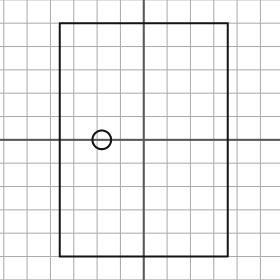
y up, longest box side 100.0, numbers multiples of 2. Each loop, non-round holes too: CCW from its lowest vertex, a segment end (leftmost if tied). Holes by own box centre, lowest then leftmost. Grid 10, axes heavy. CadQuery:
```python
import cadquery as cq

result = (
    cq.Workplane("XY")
    .moveTo(-36.0, -50.0)
    .lineTo(36.0, -50.0)
    .lineTo(36.0, 50.0)
    .lineTo(-36.0, 50.0)
    .close()
    .moveTo(-18.0, 0.0)
    .circle(4.0)
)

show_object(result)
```